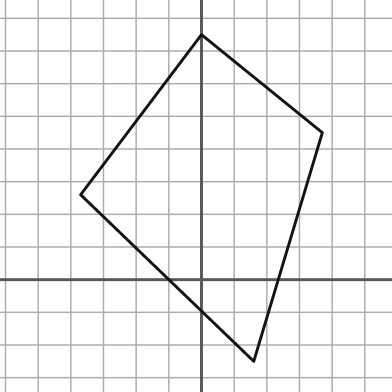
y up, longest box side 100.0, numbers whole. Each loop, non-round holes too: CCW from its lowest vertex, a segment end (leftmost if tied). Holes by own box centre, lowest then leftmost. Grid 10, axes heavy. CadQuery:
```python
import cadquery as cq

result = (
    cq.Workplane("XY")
    .moveTo(16.0, -25.0)
    .lineTo(37.0, 45.0)
    .lineTo(0.0, 75.0)
    .lineTo(-37.0, 26.0)
    .close()
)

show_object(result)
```